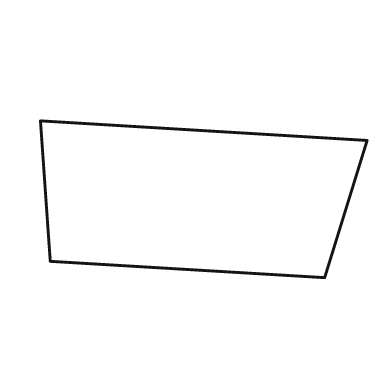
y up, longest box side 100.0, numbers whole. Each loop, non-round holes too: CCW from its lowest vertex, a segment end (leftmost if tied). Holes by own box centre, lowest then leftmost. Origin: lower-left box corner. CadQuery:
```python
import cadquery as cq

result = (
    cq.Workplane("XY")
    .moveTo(87.0, 0.0)
    .lineTo(100.0, 42.0)
    .lineTo(0.0, 48.0)
    .lineTo(3.0, 5.0)
    .close()
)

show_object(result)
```